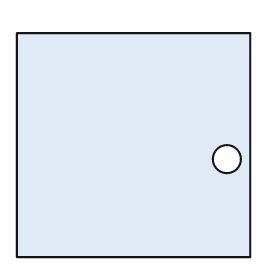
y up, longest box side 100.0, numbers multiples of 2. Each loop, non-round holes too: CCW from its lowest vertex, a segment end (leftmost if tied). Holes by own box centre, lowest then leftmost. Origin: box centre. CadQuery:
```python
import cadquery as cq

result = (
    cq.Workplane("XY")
    .moveTo(-50.0, -48.0)
    .lineTo(50.0, -48.0)
    .lineTo(50.0, 48.0)
    .lineTo(-50.0, 48.0)
    .close()
    .moveTo(40.0, -6.0)
    .circle(6.0)
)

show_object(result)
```